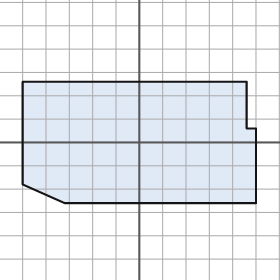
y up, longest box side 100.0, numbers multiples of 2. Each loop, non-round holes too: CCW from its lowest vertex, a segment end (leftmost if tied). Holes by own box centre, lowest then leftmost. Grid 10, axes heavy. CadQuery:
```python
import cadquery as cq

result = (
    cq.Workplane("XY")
    .moveTo(-32.0, -26.0)
    .lineTo(50.0, -26.0)
    .lineTo(50.0, 6.0)
    .lineTo(46.0, 6.0)
    .lineTo(46.0, 26.0)
    .lineTo(-50.0, 26.0)
    .lineTo(-50.0, -18.0)
    .close()
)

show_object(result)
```